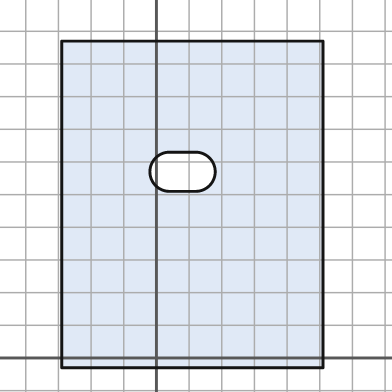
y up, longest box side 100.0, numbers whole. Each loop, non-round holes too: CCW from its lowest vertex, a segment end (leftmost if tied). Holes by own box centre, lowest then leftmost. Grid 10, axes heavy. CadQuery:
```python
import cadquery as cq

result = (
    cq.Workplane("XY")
    .moveTo(-29.0, -3.0)
    .lineTo(51.0, -3.0)
    .lineTo(51.0, 97.0)
    .lineTo(-29.0, 97.0)
    .close()
    .moveTo(4.0, 51.0)
    .lineTo(12.0, 51.0)
    .threePointArc((18.0, 57.0), (12.0, 63.0))
    .lineTo(4.0, 63.0)
    .threePointArc((-2.0, 57.0), (4.0, 51.0))
    .close()
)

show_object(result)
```